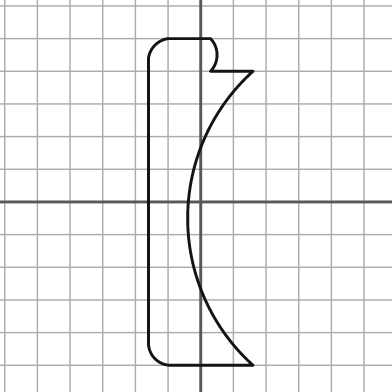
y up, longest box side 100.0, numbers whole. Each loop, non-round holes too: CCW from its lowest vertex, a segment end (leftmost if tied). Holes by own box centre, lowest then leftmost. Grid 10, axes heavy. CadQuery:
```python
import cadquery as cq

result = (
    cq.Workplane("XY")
    .moveTo(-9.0, -50.0)
    .lineTo(16.0, -50.0)
    .threePointArc((-4.0, -5.0), (16.0, 40.0))
    .lineTo(3.0, 40.0)
    .threePointArc((5.0, 45.0), (3.0, 50.0))
    .lineTo(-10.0, 50.0)
    .threePointArc((-14.0, 48.0), (-16.0, 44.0))
    .lineTo(-16.0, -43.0)
    .threePointArc((-14.0, -48.0), (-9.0, -50.0))
    .close()
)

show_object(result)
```